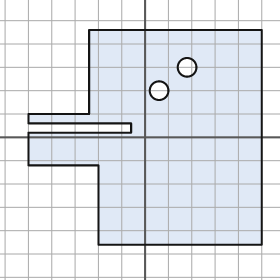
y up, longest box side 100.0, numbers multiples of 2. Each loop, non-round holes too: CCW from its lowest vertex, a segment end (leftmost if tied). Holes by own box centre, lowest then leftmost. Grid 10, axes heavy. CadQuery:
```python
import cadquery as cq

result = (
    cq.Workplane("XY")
    .moveTo(-20.0, -46.0)
    .lineTo(50.0, -46.0)
    .lineTo(50.0, 46.0)
    .lineTo(-24.0, 46.0)
    .lineTo(-24.0, 10.0)
    .lineTo(-50.0, 10.0)
    .lineTo(-50.0, 6.0)
    .lineTo(-6.0, 6.0)
    .lineTo(-6.0, 2.0)
    .lineTo(-50.0, 2.0)
    .lineTo(-50.0, -12.0)
    .lineTo(-20.0, -12.0)
    .close()
    .moveTo(6.0, 20.0)
    .circle(4.0)
    .moveTo(18.0, 30.0)
    .circle(4.0)
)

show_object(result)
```